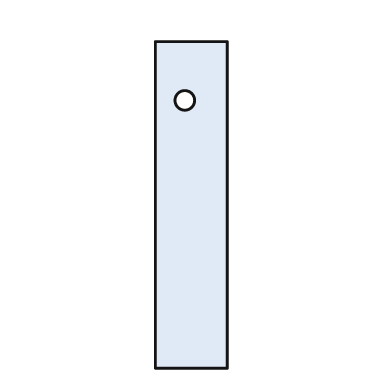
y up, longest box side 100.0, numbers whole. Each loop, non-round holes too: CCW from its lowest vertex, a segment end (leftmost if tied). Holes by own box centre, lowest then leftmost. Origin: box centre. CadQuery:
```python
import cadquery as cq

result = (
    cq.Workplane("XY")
    .moveTo(-11.0, -50.0)
    .lineTo(11.0, -50.0)
    .lineTo(11.0, 50.0)
    .lineTo(-11.0, 50.0)
    .close()
    .moveTo(-2.0, 32.0)
    .circle(3.0)
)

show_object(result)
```